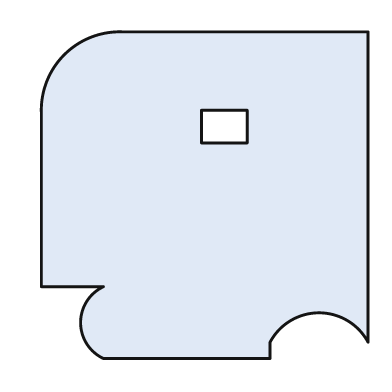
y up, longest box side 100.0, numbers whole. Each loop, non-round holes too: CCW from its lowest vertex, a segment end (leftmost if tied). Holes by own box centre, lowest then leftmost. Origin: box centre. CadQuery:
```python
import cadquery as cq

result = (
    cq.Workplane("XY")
    .moveTo(-31.0, -50.0)
    .lineTo(20.0, -50.0)
    .lineTo(20.0, -45.0)
    .threePointArc((35.0, -36.0), (50.0, -45.0))
    .lineTo(50.0, 50.0)
    .lineTo(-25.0, 50.0)
    .threePointArc((-43.0, 43.0), (-50.0, 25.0))
    .lineTo(-50.0, -28.0)
    .lineTo(-31.0, -28.0)
    .threePointArc((-38.0, -39.0), (-31.0, -50.0))
    .close()
    .moveTo(-1.0, 16.0)
    .lineTo(13.0, 16.0)
    .lineTo(13.0, 26.0)
    .lineTo(-1.0, 26.0)
    .close()
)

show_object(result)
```